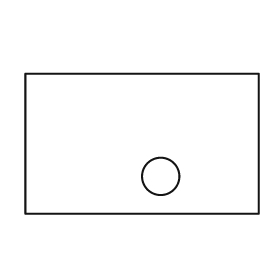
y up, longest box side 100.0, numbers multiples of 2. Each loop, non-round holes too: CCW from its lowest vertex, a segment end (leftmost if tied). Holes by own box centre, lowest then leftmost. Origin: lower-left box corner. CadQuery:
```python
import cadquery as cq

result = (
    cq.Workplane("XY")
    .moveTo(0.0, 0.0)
    .lineTo(100.0, 0.0)
    .lineTo(100.0, 60.0)
    .lineTo(0.0, 60.0)
    .close()
    .moveTo(58.0, 16.0)
    .circle(8.0)
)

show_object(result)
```